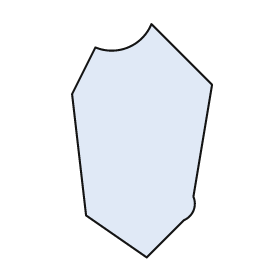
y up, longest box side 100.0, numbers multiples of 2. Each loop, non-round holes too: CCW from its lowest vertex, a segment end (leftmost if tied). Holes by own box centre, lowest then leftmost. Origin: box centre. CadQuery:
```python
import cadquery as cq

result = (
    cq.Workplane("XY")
    .moveTo(2.0, -50.0)
    .lineTo(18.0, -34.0)
    .threePointArc((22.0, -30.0), (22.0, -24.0))
    .lineTo(30.0, 24.0)
    .lineTo(4.0, 50.0)
    .threePointArc((-6.0, 40.0), (-20.0, 40.0))
    .lineTo(-30.0, 20.0)
    .lineTo(-24.0, -32.0)
    .close()
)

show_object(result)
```